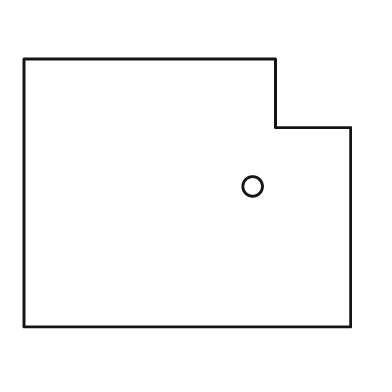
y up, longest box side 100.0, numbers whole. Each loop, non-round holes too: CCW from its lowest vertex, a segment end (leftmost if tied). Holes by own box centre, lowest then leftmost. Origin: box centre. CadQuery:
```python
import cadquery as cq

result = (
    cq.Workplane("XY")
    .moveTo(-50.0, -41.0)
    .lineTo(50.0, -41.0)
    .lineTo(50.0, 20.0)
    .lineTo(27.0, 20.0)
    .lineTo(27.0, 41.0)
    .lineTo(-50.0, 41.0)
    .close()
    .moveTo(20.0, 2.0)
    .circle(3.0)
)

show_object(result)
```